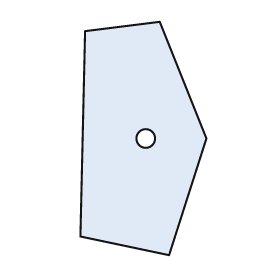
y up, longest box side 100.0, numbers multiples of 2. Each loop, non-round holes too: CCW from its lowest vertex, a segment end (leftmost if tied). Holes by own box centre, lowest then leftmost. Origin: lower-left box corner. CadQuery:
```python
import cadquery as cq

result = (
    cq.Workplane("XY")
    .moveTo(38.0, 0.0)
    .lineTo(54.0, 50.0)
    .lineTo(34.0, 100.0)
    .lineTo(2.0, 96.0)
    .lineTo(0.0, 8.0)
    .close()
    .moveTo(28.0, 50.0)
    .circle(4.0)
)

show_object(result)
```